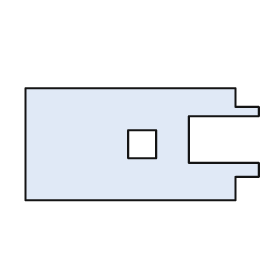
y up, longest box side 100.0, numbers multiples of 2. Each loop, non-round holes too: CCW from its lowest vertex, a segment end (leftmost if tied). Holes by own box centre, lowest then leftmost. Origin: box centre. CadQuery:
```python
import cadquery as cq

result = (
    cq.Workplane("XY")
    .moveTo(-50.0, -24.0)
    .lineTo(40.0, -24.0)
    .lineTo(40.0, -14.0)
    .lineTo(50.0, -14.0)
    .lineTo(50.0, -8.0)
    .lineTo(20.0, -8.0)
    .lineTo(20.0, 12.0)
    .lineTo(50.0, 12.0)
    .lineTo(50.0, 16.0)
    .lineTo(40.0, 16.0)
    .lineTo(40.0, 24.0)
    .lineTo(-50.0, 24.0)
    .close()
    .moveTo(-6.0, -6.0)
    .lineTo(6.0, -6.0)
    .lineTo(6.0, 6.0)
    .lineTo(-6.0, 6.0)
    .close()
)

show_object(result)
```